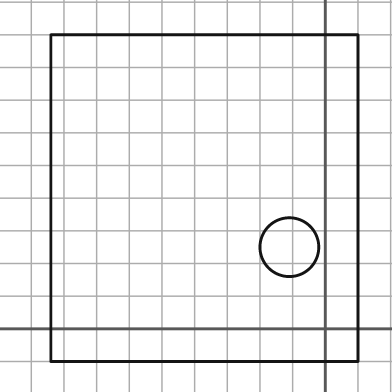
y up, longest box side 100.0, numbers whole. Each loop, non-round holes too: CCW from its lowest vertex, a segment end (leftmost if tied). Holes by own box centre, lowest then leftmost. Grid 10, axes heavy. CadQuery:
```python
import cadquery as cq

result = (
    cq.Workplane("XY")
    .moveTo(-84.0, -10.0)
    .lineTo(10.0, -10.0)
    .lineTo(10.0, 90.0)
    .lineTo(-84.0, 90.0)
    .close()
    .moveTo(-11.0, 25.0)
    .circle(9.0)
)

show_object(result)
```